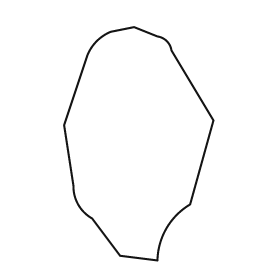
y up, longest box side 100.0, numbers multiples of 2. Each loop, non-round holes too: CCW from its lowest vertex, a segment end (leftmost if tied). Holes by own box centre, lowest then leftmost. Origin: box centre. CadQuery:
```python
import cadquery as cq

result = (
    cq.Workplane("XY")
    .moveTo(8.0, -50.0)
    .threePointArc((12.0, -36.0), (22.0, -26.0))
    .lineTo(32.0, 10.0)
    .lineTo(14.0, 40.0)
    .threePointArc((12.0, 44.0), (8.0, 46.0))
    .lineTo(-2.0, 50.0)
    .lineTo(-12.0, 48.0)
    .threePointArc((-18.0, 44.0), (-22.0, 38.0))
    .lineTo(-32.0, 8.0)
    .lineTo(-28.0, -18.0)
    .threePointArc((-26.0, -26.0), (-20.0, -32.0))
    .lineTo(-8.0, -48.0)
    .close()
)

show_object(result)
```